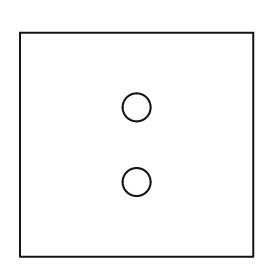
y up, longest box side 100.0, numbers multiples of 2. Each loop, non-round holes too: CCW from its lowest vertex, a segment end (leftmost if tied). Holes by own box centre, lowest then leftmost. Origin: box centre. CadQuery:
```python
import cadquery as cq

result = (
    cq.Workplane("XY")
    .moveTo(-50.0, -48.0)
    .lineTo(50.0, -48.0)
    .lineTo(50.0, 48.0)
    .lineTo(-50.0, 48.0)
    .close()
    .moveTo(0.0, -16.0)
    .circle(6.0)
    .moveTo(0.0, 16.0)
    .circle(6.0)
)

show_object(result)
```